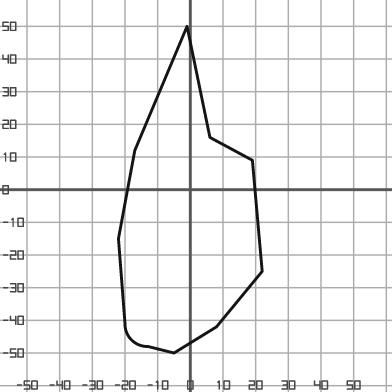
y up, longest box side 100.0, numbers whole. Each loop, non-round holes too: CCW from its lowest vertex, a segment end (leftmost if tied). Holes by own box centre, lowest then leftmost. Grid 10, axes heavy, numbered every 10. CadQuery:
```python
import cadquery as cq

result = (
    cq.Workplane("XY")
    .moveTo(-5.0, -50.0)
    .lineTo(8.0, -42.0)
    .lineTo(22.0, -25.0)
    .lineTo(19.0, 9.0)
    .lineTo(6.0, 16.0)
    .lineTo(-1.0, 50.0)
    .lineTo(-17.0, 12.0)
    .lineTo(-22.0, -15.0)
    .lineTo(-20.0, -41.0)
    .threePointArc((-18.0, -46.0), (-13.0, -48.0))
    .close()
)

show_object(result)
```